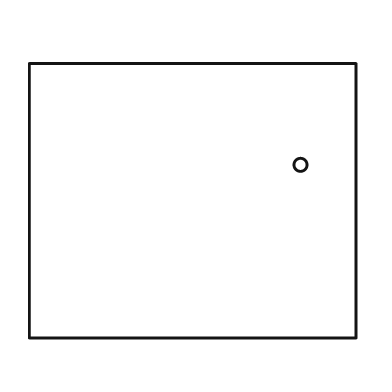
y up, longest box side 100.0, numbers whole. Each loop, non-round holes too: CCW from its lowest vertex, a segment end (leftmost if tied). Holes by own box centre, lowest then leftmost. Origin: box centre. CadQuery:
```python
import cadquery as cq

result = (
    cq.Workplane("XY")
    .moveTo(-50.0, -42.0)
    .lineTo(50.0, -42.0)
    .lineTo(50.0, 42.0)
    .lineTo(-50.0, 42.0)
    .close()
    .moveTo(33.0, 11.0)
    .circle(2.0)
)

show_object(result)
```